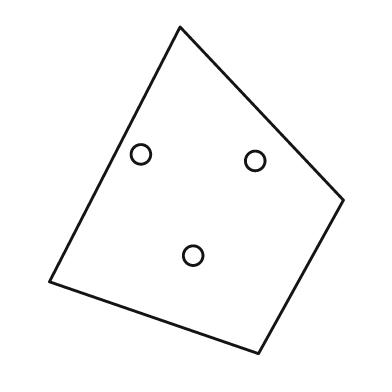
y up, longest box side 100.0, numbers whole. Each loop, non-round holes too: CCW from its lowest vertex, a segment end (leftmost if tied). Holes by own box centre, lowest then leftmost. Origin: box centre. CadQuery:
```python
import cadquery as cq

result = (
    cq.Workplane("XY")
    .moveTo(19.0, -50.0)
    .lineTo(45.0, -3.0)
    .lineTo(-5.0, 50.0)
    .lineTo(-45.0, -28.0)
    .close()
    .moveTo(-1.0, -20.0)
    .circle(3.0)
    .moveTo(18.0, 9.0)
    .circle(3.0)
    .moveTo(-17.0, 11.0)
    .circle(3.0)
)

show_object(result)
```